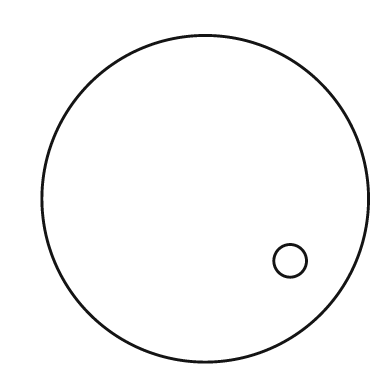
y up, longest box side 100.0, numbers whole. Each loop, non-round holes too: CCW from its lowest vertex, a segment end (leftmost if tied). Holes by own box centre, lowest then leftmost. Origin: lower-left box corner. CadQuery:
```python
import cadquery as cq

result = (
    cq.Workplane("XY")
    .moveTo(50.0, 50.0)
    .circle(50.0)
    .moveTo(76.0, 31.0)
    .circle(5.0)
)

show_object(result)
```